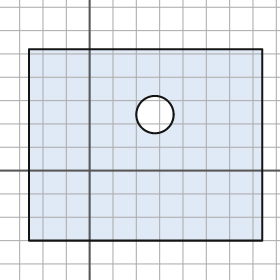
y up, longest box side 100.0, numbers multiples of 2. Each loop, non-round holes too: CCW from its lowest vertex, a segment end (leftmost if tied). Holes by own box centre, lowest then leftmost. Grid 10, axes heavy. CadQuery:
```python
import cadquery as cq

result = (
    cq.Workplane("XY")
    .moveTo(-26.0, -30.0)
    .lineTo(74.0, -30.0)
    .lineTo(74.0, 52.0)
    .lineTo(-26.0, 52.0)
    .close()
    .moveTo(28.0, 24.0)
    .circle(8.0)
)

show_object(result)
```